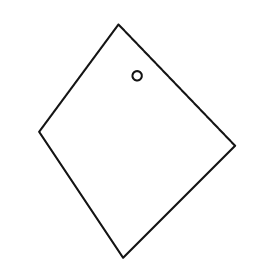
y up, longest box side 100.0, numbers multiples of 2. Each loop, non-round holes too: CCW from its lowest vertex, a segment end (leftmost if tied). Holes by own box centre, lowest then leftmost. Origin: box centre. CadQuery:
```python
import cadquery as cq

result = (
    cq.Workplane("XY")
    .moveTo(-6.0, -50.0)
    .lineTo(42.0, -2.0)
    .lineTo(-8.0, 50.0)
    .lineTo(-42.0, 4.0)
    .close()
    .moveTo(0.0, 28.0)
    .circle(2.0)
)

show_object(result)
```